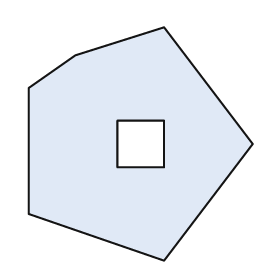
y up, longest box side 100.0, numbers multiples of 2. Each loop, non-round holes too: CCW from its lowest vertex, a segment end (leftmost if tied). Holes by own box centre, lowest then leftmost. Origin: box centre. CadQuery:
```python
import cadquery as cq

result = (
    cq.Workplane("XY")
    .moveTo(10.0, -50.0)
    .lineTo(48.0, 0.0)
    .lineTo(10.0, 50.0)
    .lineTo(-28.0, 38.0)
    .lineTo(-48.0, 24.0)
    .lineTo(-48.0, -30.0)
    .close()
    .moveTo(-10.0, -10.0)
    .lineTo(10.0, -10.0)
    .lineTo(10.0, 10.0)
    .lineTo(-10.0, 10.0)
    .close()
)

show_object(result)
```